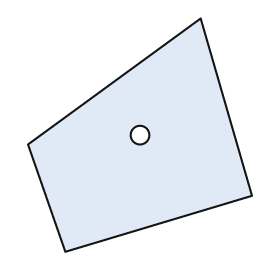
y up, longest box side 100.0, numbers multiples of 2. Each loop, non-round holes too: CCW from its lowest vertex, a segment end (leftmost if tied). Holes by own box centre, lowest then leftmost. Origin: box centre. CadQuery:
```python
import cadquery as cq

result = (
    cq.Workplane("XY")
    .moveTo(-32.0, -50.0)
    .lineTo(48.0, -26.0)
    .lineTo(26.0, 50.0)
    .lineTo(-48.0, -4.0)
    .close()
    .moveTo(0.0, 0.0)
    .circle(4.0)
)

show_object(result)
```